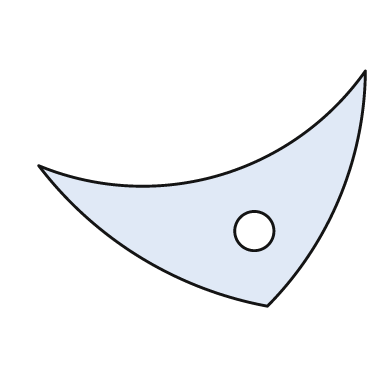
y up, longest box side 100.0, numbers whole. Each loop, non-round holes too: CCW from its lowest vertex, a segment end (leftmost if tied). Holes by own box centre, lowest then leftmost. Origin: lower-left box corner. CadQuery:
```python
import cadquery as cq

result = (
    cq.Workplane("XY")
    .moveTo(70.0, 0.0)
    .threePointArc((92.0, 33.0), (100.0, 72.0))
    .threePointArc((55.0, 40.0), (0.0, 43.0))
    .threePointArc((31.0, 15.0), (70.0, 0.0))
    .close()
    .moveTo(66.0, 23.0)
    .circle(6.0)
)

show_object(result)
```